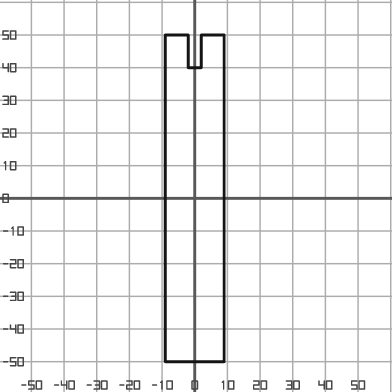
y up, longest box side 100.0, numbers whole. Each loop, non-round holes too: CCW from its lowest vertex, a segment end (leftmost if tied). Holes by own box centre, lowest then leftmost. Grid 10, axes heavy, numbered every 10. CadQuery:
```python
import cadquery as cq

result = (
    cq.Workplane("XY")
    .moveTo(-9.0, -50.0)
    .lineTo(9.0, -50.0)
    .lineTo(9.0, 50.0)
    .lineTo(2.0, 50.0)
    .lineTo(2.0, 40.0)
    .lineTo(-2.0, 40.0)
    .lineTo(-2.0, 50.0)
    .lineTo(-9.0, 50.0)
    .close()
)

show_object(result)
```